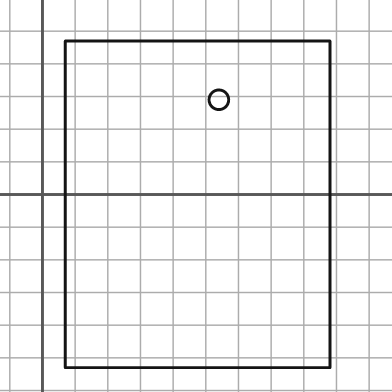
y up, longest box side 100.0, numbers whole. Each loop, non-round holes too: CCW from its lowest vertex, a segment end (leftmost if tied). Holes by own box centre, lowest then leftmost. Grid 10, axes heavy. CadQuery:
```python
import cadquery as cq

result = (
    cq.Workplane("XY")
    .moveTo(7.0, -53.0)
    .lineTo(88.0, -53.0)
    .lineTo(88.0, 47.0)
    .lineTo(7.0, 47.0)
    .close()
    .moveTo(54.0, 29.0)
    .circle(3.0)
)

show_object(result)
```